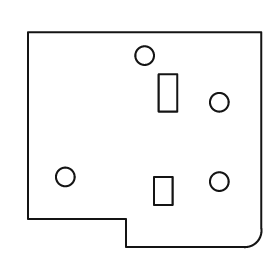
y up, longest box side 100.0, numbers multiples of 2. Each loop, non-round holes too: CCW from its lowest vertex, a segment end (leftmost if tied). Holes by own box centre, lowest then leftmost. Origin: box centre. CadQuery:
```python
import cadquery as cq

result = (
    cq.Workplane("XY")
    .moveTo(-8.0, -46.0)
    .lineTo(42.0, -46.0)
    .threePointArc((48.0, -44.0), (50.0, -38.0))
    .lineTo(50.0, 46.0)
    .lineTo(-50.0, 46.0)
    .lineTo(-50.0, -34.0)
    .lineTo(-8.0, -34.0)
    .close()
    .moveTo(4.0, -28.0)
    .lineTo(12.0, -28.0)
    .lineTo(12.0, -16.0)
    .lineTo(4.0, -16.0)
    .close()
    .moveTo(32.0, -18.0)
    .circle(4.0)
    .moveTo(-34.0, -16.0)
    .circle(4.0)
    .moveTo(32.0, 16.0)
    .circle(4.0)
    .moveTo(6.0, 12.0)
    .lineTo(14.0, 12.0)
    .lineTo(14.0, 28.0)
    .lineTo(6.0, 28.0)
    .close()
    .moveTo(0.0, 36.0)
    .circle(4.0)
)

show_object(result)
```